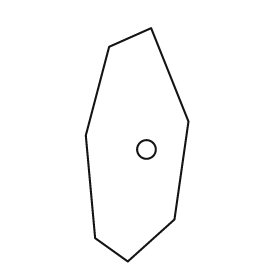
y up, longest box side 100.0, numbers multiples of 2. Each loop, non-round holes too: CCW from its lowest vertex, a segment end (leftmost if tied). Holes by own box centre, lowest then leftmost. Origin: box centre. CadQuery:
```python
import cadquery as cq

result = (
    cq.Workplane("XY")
    .moveTo(-4.0, -50.0)
    .lineTo(16.0, -32.0)
    .lineTo(22.0, 10.0)
    .lineTo(6.0, 50.0)
    .lineTo(-12.0, 42.0)
    .lineTo(-22.0, 4.0)
    .lineTo(-18.0, -40.0)
    .close()
    .moveTo(4.0, -2.0)
    .circle(4.0)
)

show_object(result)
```